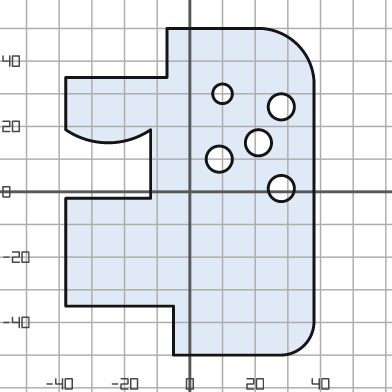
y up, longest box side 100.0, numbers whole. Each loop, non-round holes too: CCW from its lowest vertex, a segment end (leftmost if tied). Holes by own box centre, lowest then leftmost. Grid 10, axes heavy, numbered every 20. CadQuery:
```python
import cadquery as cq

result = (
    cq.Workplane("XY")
    .moveTo(-5.0, -50.0)
    .lineTo(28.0, -50.0)
    .threePointArc((35.0, -47.0), (38.0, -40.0))
    .lineTo(38.0, 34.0)
    .threePointArc((33.0, 45.0), (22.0, 50.0))
    .lineTo(-7.0, 50.0)
    .lineTo(-7.0, 35.0)
    .lineTo(-38.0, 35.0)
    .lineTo(-38.0, 19.0)
    .threePointArc((-25.0, 15.0), (-12.0, 19.0))
    .lineTo(-12.0, -2.0)
    .lineTo(-38.0, -2.0)
    .lineTo(-38.0, -35.0)
    .lineTo(-5.0, -35.0)
    .close()
    .moveTo(28.0, 1.0)
    .circle(4.0)
    .moveTo(9.0, 10.0)
    .circle(4.0)
    .moveTo(21.0, 15.0)
    .circle(4.0)
    .moveTo(28.0, 26.0)
    .circle(4.0)
    .moveTo(10.0, 30.0)
    .circle(3.0)
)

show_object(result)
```